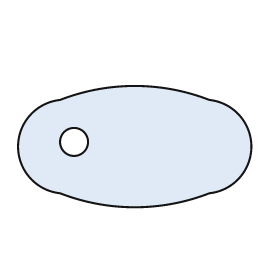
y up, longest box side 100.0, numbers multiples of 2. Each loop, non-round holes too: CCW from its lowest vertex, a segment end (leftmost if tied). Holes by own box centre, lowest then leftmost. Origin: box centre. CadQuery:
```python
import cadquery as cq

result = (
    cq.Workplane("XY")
    .moveTo(-32.0, -20.0)
    .threePointArc((0.0, -26.0), (32.0, -20.0))
    .threePointArc((50.0, 0.0), (32.0, 20.0))
    .threePointArc((0.0, 26.0), (-32.0, 20.0))
    .threePointArc((-50.0, 0.0), (-32.0, -20.0))
    .close()
    .moveTo(-26.0, 2.0)
    .circle(6.0)
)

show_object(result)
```